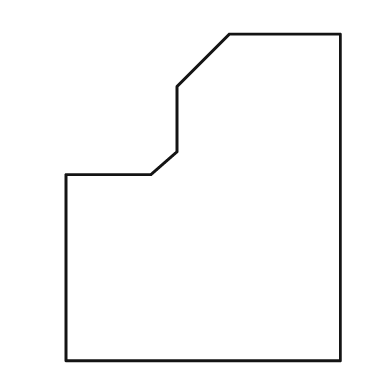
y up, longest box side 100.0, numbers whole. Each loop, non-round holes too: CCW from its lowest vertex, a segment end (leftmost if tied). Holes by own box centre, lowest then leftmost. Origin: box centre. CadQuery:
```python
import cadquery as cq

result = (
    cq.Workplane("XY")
    .moveTo(-42.0, -50.0)
    .lineTo(42.0, -50.0)
    .lineTo(42.0, 50.0)
    .lineTo(8.0, 50.0)
    .lineTo(-8.0, 34.0)
    .lineTo(-8.0, 14.0)
    .lineTo(-16.0, 7.0)
    .lineTo(-42.0, 7.0)
    .close()
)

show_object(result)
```